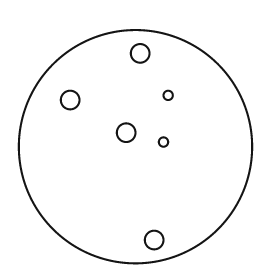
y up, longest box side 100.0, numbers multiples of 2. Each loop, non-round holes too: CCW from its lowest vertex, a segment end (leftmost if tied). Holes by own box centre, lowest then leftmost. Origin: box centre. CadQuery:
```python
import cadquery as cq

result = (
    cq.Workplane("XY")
    .moveTo(0.0, 0.0)
    .circle(50.0)
    .moveTo(8.0, -40.0)
    .circle(4.0)
    .moveTo(12.0, 2.0)
    .circle(2.0)
    .moveTo(-4.0, 6.0)
    .circle(4.0)
    .moveTo(-28.0, 20.0)
    .circle(4.0)
    .moveTo(14.0, 22.0)
    .circle(2.0)
    .moveTo(2.0, 40.0)
    .circle(4.0)
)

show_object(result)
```